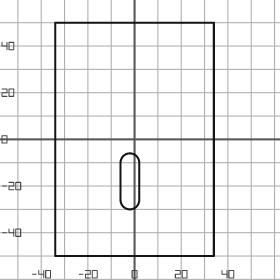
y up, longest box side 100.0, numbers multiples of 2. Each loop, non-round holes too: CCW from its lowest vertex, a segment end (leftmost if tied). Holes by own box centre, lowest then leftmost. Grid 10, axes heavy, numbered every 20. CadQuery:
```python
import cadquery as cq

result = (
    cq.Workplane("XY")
    .moveTo(-34.0, -50.0)
    .lineTo(34.0, -50.0)
    .lineTo(34.0, 50.0)
    .lineTo(-34.0, 50.0)
    .close()
    .moveTo(-6.0, -26.0)
    .threePointArc((-2.0, -30.0), (2.0, -26.0))
    .lineTo(2.0, -10.0)
    .threePointArc((-2.0, -6.0), (-6.0, -10.0))
    .close()
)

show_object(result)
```